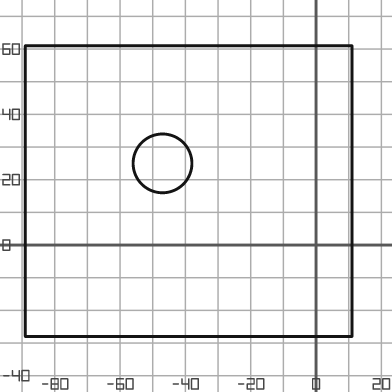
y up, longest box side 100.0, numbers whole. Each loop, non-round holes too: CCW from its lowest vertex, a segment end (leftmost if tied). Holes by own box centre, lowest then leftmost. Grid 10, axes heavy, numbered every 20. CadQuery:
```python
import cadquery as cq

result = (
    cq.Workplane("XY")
    .moveTo(-89.0, -28.0)
    .lineTo(11.0, -28.0)
    .lineTo(11.0, 61.0)
    .lineTo(-89.0, 61.0)
    .close()
    .moveTo(-47.0, 25.0)
    .circle(9.0)
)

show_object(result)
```